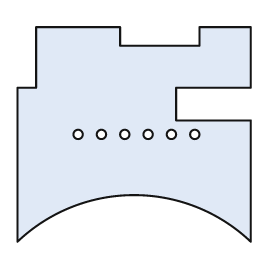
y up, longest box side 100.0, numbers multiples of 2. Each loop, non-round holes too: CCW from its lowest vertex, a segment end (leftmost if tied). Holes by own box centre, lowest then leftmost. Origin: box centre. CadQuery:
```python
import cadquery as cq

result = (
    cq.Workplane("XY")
    .moveTo(-50.0, -46.0)
    .threePointArc((0.0, -26.0), (50.0, -46.0))
    .lineTo(50.0, 6.0)
    .lineTo(18.0, 6.0)
    .lineTo(18.0, 20.0)
    .lineTo(50.0, 20.0)
    .lineTo(50.0, 46.0)
    .lineTo(28.0, 46.0)
    .lineTo(28.0, 38.0)
    .lineTo(-6.0, 38.0)
    .lineTo(-6.0, 46.0)
    .lineTo(-42.0, 46.0)
    .lineTo(-42.0, 20.0)
    .lineTo(-50.0, 20.0)
    .close()
    .moveTo(-24.0, 0.0)
    .circle(2.0)
    .moveTo(-14.0, 0.0)
    .circle(2.0)
    .moveTo(-4.0, 0.0)
    .circle(2.0)
    .moveTo(6.0, 0.0)
    .circle(2.0)
    .moveTo(16.0, 0.0)
    .circle(2.0)
    .moveTo(26.0, 0.0)
    .circle(2.0)
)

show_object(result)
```